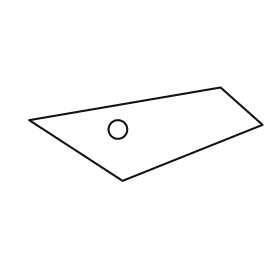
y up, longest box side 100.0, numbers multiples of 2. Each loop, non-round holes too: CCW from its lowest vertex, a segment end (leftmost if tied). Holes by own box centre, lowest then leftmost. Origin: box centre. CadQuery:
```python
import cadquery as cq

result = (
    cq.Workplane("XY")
    .moveTo(-10.0, -20.0)
    .lineTo(50.0, 4.0)
    .lineTo(32.0, 20.0)
    .lineTo(-50.0, 6.0)
    .close()
    .moveTo(-12.0, 2.0)
    .circle(4.0)
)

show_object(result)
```